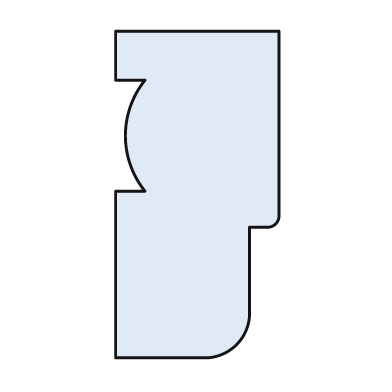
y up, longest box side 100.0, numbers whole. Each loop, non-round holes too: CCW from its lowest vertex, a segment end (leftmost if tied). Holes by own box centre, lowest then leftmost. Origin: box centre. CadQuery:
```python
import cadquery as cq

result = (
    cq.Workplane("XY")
    .moveTo(-25.0, -50.0)
    .lineTo(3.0, -50.0)
    .threePointArc((12.0, -46.0), (16.0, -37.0))
    .lineTo(16.0, -10.0)
    .lineTo(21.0, -10.0)
    .threePointArc((24.0, -9.0), (25.0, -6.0))
    .lineTo(25.0, 50.0)
    .lineTo(-25.0, 50.0)
    .lineTo(-25.0, 35.0)
    .lineTo(-16.0, 35.0)
    .threePointArc((-22.0, 18.0), (-16.0, 1.0))
    .lineTo(-25.0, 1.0)
    .close()
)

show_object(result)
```